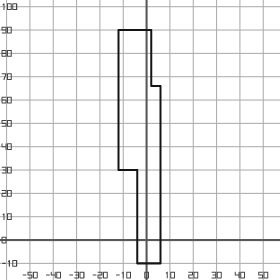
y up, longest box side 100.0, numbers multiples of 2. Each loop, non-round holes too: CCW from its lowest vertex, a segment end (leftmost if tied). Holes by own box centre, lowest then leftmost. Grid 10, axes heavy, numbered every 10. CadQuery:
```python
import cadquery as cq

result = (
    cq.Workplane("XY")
    .moveTo(-4.0, -10.0)
    .lineTo(6.0, -10.0)
    .lineTo(6.0, 66.0)
    .lineTo(2.0, 66.0)
    .lineTo(2.0, 90.0)
    .lineTo(-12.0, 90.0)
    .lineTo(-12.0, 30.0)
    .lineTo(-4.0, 30.0)
    .close()
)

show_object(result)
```